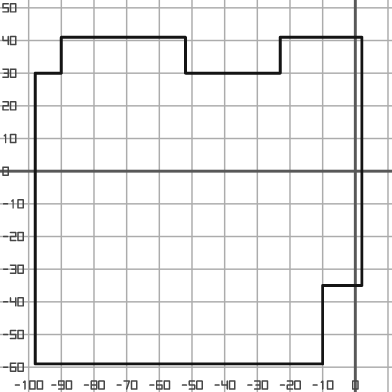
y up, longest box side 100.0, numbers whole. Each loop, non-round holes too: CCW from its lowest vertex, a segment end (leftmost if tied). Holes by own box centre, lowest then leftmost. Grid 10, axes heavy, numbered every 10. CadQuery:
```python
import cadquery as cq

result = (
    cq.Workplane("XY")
    .moveTo(-98.0, -59.0)
    .lineTo(-10.0, -59.0)
    .lineTo(-10.0, -35.0)
    .lineTo(2.0, -35.0)
    .lineTo(2.0, 41.0)
    .lineTo(-23.0, 41.0)
    .lineTo(-23.0, 30.0)
    .lineTo(-52.0, 30.0)
    .lineTo(-52.0, 41.0)
    .lineTo(-90.0, 41.0)
    .lineTo(-90.0, 30.0)
    .lineTo(-98.0, 30.0)
    .close()
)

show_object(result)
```